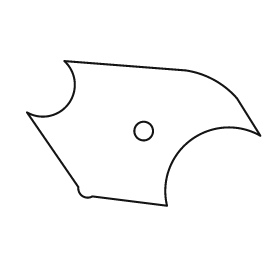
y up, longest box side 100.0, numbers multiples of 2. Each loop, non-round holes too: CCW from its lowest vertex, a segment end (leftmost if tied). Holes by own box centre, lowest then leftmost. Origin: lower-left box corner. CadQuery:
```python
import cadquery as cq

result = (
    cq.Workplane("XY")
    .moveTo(60.0, 0.0)
    .threePointArc((70.0, 28.0), (100.0, 30.0))
    .lineTo(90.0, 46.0)
    .threePointArc((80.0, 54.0), (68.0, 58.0))
    .lineTo(16.0, 62.0)
    .threePointArc((18.0, 44.0), (0.0, 40.0))
    .lineTo(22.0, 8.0)
    .threePointArc((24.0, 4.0), (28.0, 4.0))
    .close()
    .moveTo(50.0, 32.0)
    .circle(4.0)
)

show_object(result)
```